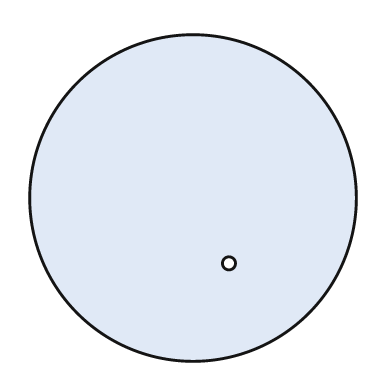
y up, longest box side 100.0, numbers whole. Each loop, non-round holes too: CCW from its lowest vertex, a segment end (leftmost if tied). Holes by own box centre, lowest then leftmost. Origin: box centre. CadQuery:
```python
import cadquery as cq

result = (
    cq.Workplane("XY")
    .moveTo(0.0, 0.0)
    .circle(50.0)
    .moveTo(11.0, -20.0)
    .circle(2.0)
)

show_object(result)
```